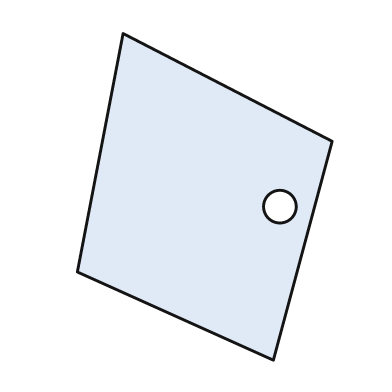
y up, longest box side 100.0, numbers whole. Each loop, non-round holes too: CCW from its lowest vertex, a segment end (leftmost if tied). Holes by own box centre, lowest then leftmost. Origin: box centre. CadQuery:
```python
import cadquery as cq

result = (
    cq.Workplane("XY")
    .moveTo(21.0, -50.0)
    .lineTo(39.0, 17.0)
    .lineTo(-25.0, 50.0)
    .lineTo(-39.0, -23.0)
    .close()
    .moveTo(23.0, -3.0)
    .circle(5.0)
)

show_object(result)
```